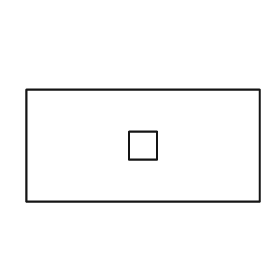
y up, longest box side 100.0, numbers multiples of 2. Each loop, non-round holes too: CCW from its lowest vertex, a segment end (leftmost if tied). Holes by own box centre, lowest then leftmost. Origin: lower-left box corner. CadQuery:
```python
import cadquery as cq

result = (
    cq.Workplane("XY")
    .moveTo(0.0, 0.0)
    .lineTo(100.0, 0.0)
    .lineTo(100.0, 48.0)
    .lineTo(0.0, 48.0)
    .close()
    .moveTo(44.0, 18.0)
    .lineTo(56.0, 18.0)
    .lineTo(56.0, 30.0)
    .lineTo(44.0, 30.0)
    .close()
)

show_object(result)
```